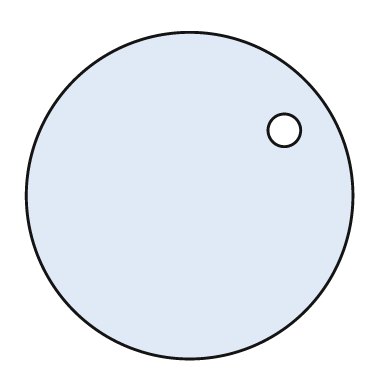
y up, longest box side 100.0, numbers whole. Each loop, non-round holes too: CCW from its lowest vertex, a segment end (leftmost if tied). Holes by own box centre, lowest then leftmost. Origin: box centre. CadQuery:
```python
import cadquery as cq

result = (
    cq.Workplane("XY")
    .moveTo(0.0, 0.0)
    .circle(50.0)
    .moveTo(29.0, 20.0)
    .circle(5.0)
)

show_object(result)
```